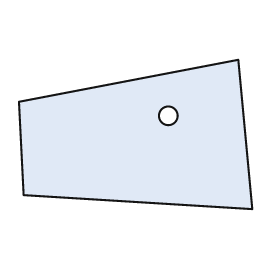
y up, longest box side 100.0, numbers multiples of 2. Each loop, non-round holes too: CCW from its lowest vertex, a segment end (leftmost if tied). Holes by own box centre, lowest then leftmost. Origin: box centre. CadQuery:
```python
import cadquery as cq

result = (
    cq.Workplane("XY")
    .moveTo(50.0, -32.0)
    .lineTo(44.0, 32.0)
    .lineTo(-50.0, 14.0)
    .lineTo(-48.0, -26.0)
    .close()
    .moveTo(14.0, 8.0)
    .circle(4.0)
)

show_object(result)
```